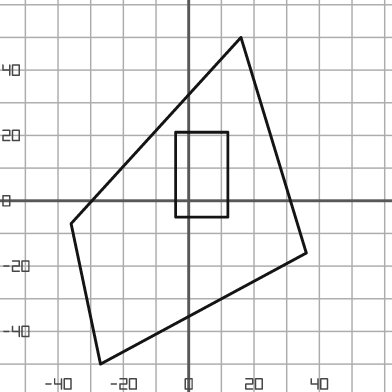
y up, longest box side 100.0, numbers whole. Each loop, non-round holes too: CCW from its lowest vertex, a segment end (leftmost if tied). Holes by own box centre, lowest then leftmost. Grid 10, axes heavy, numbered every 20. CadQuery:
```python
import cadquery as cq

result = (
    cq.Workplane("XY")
    .moveTo(-27.0, -50.0)
    .lineTo(36.0, -16.0)
    .lineTo(16.0, 50.0)
    .lineTo(-36.0, -7.0)
    .close()
    .moveTo(-4.0, -5.0)
    .lineTo(12.0, -5.0)
    .lineTo(12.0, 21.0)
    .lineTo(-4.0, 21.0)
    .close()
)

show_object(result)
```